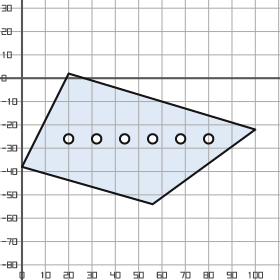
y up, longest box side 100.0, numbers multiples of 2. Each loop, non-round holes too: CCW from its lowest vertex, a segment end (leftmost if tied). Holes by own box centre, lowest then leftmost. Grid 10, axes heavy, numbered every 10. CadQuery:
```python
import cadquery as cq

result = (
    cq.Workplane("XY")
    .moveTo(56.0, -54.0)
    .lineTo(100.0, -22.0)
    .lineTo(20.0, 2.0)
    .lineTo(0.0, -38.0)
    .close()
    .moveTo(20.0, -26.0)
    .circle(2.0)
    .moveTo(32.0, -26.0)
    .circle(2.0)
    .moveTo(44.0, -26.0)
    .circle(2.0)
    .moveTo(56.0, -26.0)
    .circle(2.0)
    .moveTo(68.0, -26.0)
    .circle(2.0)
    .moveTo(80.0, -26.0)
    .circle(2.0)
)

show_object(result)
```